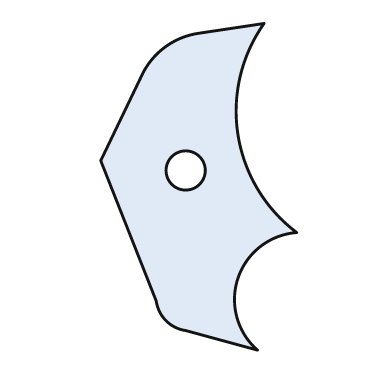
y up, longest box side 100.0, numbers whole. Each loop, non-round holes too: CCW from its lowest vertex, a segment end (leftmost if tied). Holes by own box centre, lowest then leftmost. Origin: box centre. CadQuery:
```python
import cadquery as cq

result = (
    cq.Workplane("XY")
    .moveTo(18.0, -50.0)
    .threePointArc((12.0, -28.0), (30.0, -14.0))
    .threePointArc((12.0, 16.0), (20.0, 50.0))
    .lineTo(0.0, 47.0)
    .threePointArc((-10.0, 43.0), (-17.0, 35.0))
    .lineTo(-30.0, 8.0)
    .lineTo(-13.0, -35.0)
    .threePointArc((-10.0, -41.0), (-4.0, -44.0))
    .close()
    .moveTo(-4.0, 5.0)
    .circle(6.0)
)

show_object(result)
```